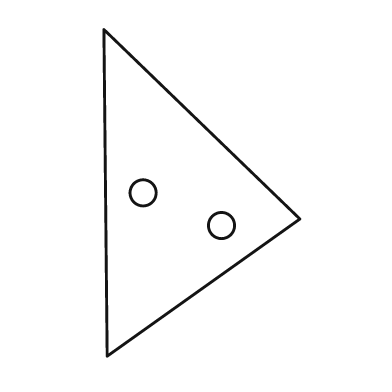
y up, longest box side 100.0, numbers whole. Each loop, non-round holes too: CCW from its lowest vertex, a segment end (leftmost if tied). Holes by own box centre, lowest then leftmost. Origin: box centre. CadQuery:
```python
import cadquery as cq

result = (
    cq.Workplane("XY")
    .moveTo(-29.0, -50.0)
    .lineTo(30.0, -8.0)
    .lineTo(-30.0, 50.0)
    .close()
    .moveTo(6.0, -10.0)
    .circle(4.0)
    .moveTo(-18.0, 0.0)
    .circle(4.0)
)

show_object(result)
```